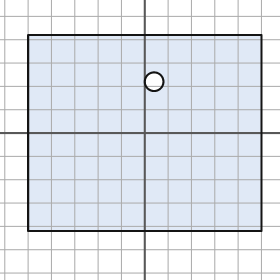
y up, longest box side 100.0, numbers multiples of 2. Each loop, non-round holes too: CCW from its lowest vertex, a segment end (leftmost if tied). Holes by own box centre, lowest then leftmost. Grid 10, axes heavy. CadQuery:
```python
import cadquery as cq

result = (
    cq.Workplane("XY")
    .moveTo(-50.0, -42.0)
    .lineTo(50.0, -42.0)
    .lineTo(50.0, 42.0)
    .lineTo(-50.0, 42.0)
    .close()
    .moveTo(4.0, 22.0)
    .circle(4.0)
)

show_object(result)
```